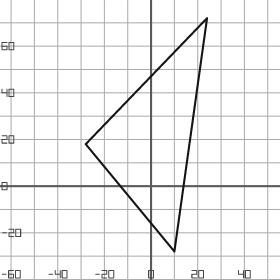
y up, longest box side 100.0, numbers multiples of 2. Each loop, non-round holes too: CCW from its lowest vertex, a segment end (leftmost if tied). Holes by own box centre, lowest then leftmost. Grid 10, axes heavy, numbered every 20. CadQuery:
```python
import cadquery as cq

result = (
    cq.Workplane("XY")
    .moveTo(10.0, -28.0)
    .lineTo(24.0, 72.0)
    .lineTo(-28.0, 18.0)
    .close()
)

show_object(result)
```